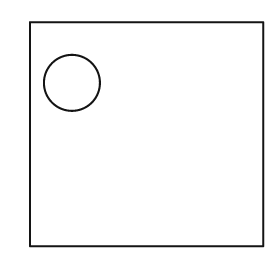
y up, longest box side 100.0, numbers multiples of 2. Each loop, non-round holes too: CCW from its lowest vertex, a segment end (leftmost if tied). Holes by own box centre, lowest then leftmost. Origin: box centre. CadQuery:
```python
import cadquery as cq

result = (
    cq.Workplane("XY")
    .moveTo(-50.0, -48.0)
    .lineTo(50.0, -48.0)
    .lineTo(50.0, 48.0)
    .lineTo(-50.0, 48.0)
    .close()
    .moveTo(-32.0, 22.0)
    .circle(12.0)
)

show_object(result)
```